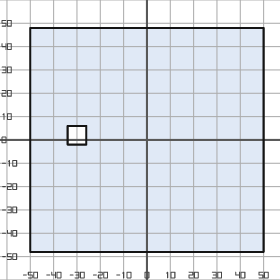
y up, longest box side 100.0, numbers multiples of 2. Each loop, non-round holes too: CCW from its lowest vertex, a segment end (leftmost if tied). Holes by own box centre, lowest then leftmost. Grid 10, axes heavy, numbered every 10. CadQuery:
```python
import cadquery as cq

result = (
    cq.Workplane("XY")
    .moveTo(-50.0, -48.0)
    .lineTo(50.0, -48.0)
    .lineTo(50.0, 48.0)
    .lineTo(-50.0, 48.0)
    .close()
    .moveTo(-34.0, -2.0)
    .lineTo(-26.0, -2.0)
    .lineTo(-26.0, 6.0)
    .lineTo(-34.0, 6.0)
    .close()
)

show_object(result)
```